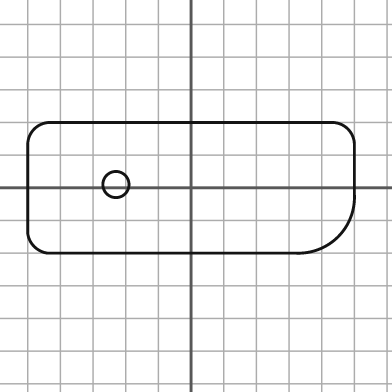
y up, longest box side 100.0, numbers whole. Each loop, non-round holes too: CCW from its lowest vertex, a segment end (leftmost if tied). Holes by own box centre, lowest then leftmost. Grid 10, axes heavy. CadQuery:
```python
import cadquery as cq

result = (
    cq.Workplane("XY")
    .moveTo(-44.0, -20.0)
    .lineTo(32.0, -20.0)
    .threePointArc((45.0, -15.0), (50.0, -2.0))
    .lineTo(50.0, 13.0)
    .threePointArc((48.0, 18.0), (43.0, 20.0))
    .lineTo(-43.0, 20.0)
    .threePointArc((-48.0, 18.0), (-50.0, 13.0))
    .lineTo(-50.0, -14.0)
    .threePointArc((-48.0, -18.0), (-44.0, -20.0))
    .close()
    .moveTo(-23.0, 1.0)
    .circle(4.0)
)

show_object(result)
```